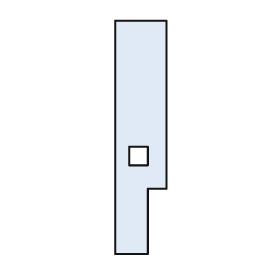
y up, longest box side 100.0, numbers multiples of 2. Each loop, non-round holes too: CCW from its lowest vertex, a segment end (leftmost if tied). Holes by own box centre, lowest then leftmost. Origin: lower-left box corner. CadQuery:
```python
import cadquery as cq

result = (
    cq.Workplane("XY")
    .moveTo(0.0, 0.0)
    .lineTo(14.0, 0.0)
    .lineTo(14.0, 28.0)
    .lineTo(22.0, 28.0)
    .lineTo(22.0, 100.0)
    .lineTo(0.0, 100.0)
    .close()
    .moveTo(6.0, 38.0)
    .lineTo(14.0, 38.0)
    .lineTo(14.0, 46.0)
    .lineTo(6.0, 46.0)
    .close()
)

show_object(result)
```